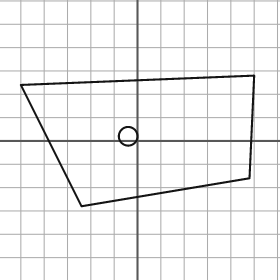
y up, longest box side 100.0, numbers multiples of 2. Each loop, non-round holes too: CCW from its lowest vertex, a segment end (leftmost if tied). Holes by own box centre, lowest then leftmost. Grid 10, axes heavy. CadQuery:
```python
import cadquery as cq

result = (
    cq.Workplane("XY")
    .moveTo(-24.0, -28.0)
    .lineTo(48.0, -16.0)
    .lineTo(50.0, 28.0)
    .lineTo(-50.0, 24.0)
    .close()
    .moveTo(-4.0, 2.0)
    .circle(4.0)
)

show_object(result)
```